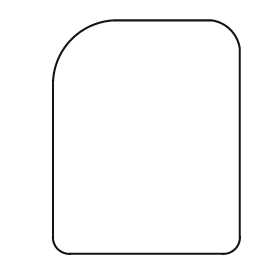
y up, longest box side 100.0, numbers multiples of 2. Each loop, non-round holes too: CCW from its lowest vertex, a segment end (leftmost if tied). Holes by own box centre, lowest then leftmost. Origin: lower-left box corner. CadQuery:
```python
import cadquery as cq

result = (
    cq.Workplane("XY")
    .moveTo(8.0, 0.0)
    .lineTo(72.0, 0.0)
    .threePointArc((78.0, 2.0), (80.0, 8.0))
    .lineTo(80.0, 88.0)
    .threePointArc((76.0, 96.0), (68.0, 100.0))
    .lineTo(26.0, 100.0)
    .threePointArc((8.0, 92.0), (0.0, 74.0))
    .lineTo(0.0, 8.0)
    .threePointArc((2.0, 2.0), (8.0, 0.0))
    .close()
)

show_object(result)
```